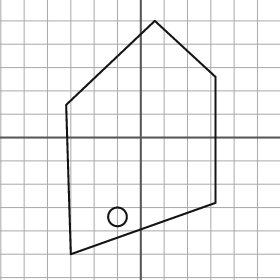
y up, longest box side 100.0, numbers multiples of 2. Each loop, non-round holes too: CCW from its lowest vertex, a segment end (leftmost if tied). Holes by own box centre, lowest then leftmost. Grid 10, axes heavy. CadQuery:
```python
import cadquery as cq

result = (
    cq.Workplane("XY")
    .moveTo(-30.0, -50.0)
    .lineTo(32.0, -28.0)
    .lineTo(32.0, 26.0)
    .lineTo(6.0, 50.0)
    .lineTo(-32.0, 14.0)
    .close()
    .moveTo(-10.0, -34.0)
    .circle(4.0)
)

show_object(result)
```